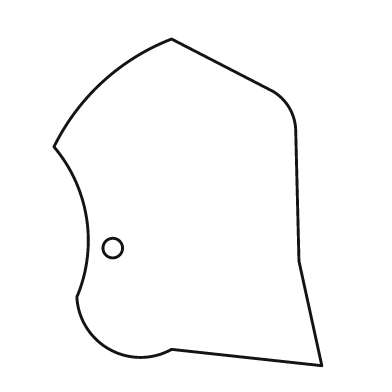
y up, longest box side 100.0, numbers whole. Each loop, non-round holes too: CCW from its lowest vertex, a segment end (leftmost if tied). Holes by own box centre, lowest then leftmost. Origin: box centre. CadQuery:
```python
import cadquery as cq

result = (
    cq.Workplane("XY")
    .moveTo(41.0, -50.0)
    .lineTo(34.0, -18.0)
    .lineTo(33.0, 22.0)
    .threePointArc((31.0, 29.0), (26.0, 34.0))
    .lineTo(-5.0, 50.0)
    .threePointArc((-26.0, 37.0), (-41.0, 17.0))
    .threePointArc((-31.0, -5.0), (-34.0, -29.0))
    .threePointArc((-24.0, -45.0), (-5.0, -45.0))
    .close()
    .moveTo(-23.0, -14.0)
    .circle(3.0)
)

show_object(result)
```